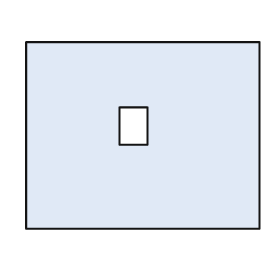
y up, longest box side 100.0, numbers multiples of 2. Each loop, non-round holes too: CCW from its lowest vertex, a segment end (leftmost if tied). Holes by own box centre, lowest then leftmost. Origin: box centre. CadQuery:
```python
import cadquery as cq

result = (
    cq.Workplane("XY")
    .moveTo(-50.0, -40.0)
    .lineTo(50.0, -40.0)
    .lineTo(50.0, 40.0)
    .lineTo(-50.0, 40.0)
    .close()
    .moveTo(-10.0, -4.0)
    .lineTo(2.0, -4.0)
    .lineTo(2.0, 12.0)
    .lineTo(-10.0, 12.0)
    .close()
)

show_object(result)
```